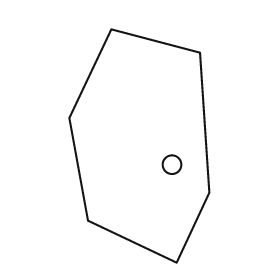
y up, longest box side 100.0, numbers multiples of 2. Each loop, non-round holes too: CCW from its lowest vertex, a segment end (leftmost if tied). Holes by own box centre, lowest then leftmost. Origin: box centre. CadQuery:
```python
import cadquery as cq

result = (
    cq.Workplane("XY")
    .moveTo(16.0, -50.0)
    .lineTo(30.0, -20.0)
    .lineTo(26.0, 40.0)
    .lineTo(-12.0, 50.0)
    .lineTo(-30.0, 12.0)
    .lineTo(-22.0, -32.0)
    .close()
    .moveTo(14.0, -8.0)
    .circle(4.0)
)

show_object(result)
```